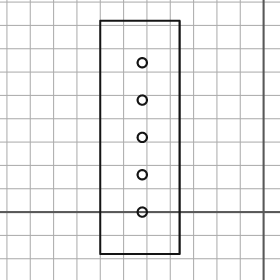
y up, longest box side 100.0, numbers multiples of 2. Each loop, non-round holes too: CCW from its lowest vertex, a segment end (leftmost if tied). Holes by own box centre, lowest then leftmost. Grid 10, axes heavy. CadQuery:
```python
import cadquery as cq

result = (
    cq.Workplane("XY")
    .moveTo(-70.0, -18.0)
    .lineTo(-36.0, -18.0)
    .lineTo(-36.0, 82.0)
    .lineTo(-70.0, 82.0)
    .close()
    .moveTo(-52.0, 0.0)
    .circle(2.0)
    .moveTo(-52.0, 16.0)
    .circle(2.0)
    .moveTo(-52.0, 32.0)
    .circle(2.0)
    .moveTo(-52.0, 48.0)
    .circle(2.0)
    .moveTo(-52.0, 64.0)
    .circle(2.0)
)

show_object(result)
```